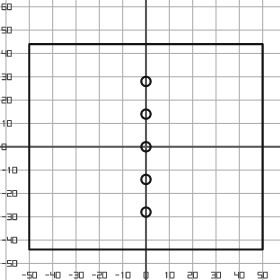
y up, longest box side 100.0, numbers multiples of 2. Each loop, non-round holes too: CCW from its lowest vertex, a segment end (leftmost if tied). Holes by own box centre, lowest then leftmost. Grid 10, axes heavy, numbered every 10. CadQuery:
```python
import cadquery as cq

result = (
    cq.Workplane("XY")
    .moveTo(-50.0, -44.0)
    .lineTo(50.0, -44.0)
    .lineTo(50.0, 44.0)
    .lineTo(-50.0, 44.0)
    .close()
    .moveTo(0.0, -28.0)
    .circle(2.0)
    .moveTo(0.0, -14.0)
    .circle(2.0)
    .moveTo(0.0, 0.0)
    .circle(2.0)
    .moveTo(0.0, 14.0)
    .circle(2.0)
    .moveTo(0.0, 28.0)
    .circle(2.0)
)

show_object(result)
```